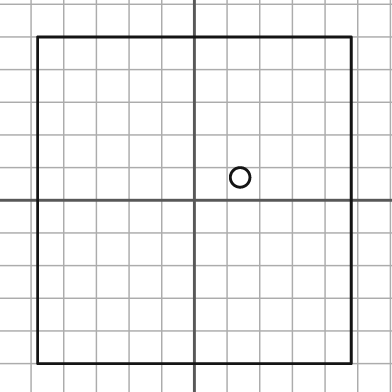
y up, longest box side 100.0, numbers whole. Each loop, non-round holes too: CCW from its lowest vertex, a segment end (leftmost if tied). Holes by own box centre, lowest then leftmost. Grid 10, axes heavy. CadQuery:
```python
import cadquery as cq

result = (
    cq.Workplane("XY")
    .moveTo(-48.0, -50.0)
    .lineTo(48.0, -50.0)
    .lineTo(48.0, 50.0)
    .lineTo(-48.0, 50.0)
    .close()
    .moveTo(14.0, 7.0)
    .circle(3.0)
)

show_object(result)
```